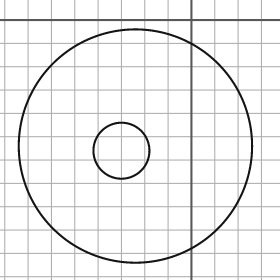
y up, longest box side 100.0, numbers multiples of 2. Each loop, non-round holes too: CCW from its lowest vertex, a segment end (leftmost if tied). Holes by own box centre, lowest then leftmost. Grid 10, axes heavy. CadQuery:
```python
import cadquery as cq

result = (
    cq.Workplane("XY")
    .moveTo(-24.0, -54.0)
    .circle(50.0)
    .moveTo(-30.0, -56.0)
    .circle(12.0)
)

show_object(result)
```